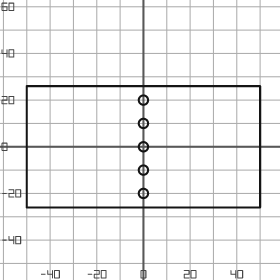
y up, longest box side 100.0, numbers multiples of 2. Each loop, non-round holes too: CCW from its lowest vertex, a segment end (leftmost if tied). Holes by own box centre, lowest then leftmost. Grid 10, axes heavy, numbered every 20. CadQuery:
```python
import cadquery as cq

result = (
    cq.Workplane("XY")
    .moveTo(-50.0, -26.0)
    .lineTo(50.0, -26.0)
    .lineTo(50.0, 26.0)
    .lineTo(-50.0, 26.0)
    .close()
    .moveTo(0.0, -20.0)
    .circle(2.0)
    .moveTo(0.0, -10.0)
    .circle(2.0)
    .moveTo(0.0, 0.0)
    .circle(2.0)
    .moveTo(0.0, 10.0)
    .circle(2.0)
    .moveTo(0.0, 20.0)
    .circle(2.0)
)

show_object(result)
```